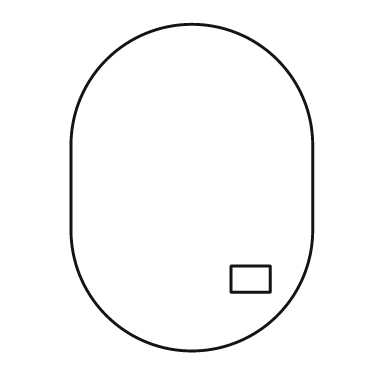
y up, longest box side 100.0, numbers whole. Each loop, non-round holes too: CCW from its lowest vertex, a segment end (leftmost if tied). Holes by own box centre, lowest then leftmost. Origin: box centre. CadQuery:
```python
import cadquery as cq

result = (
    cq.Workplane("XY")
    .moveTo(-37.0, -13.0)
    .threePointArc((0.0, -50.0), (37.0, -13.0))
    .lineTo(37.0, 13.0)
    .threePointArc((0.0, 50.0), (-37.0, 13.0))
    .close()
    .moveTo(12.0, -32.0)
    .lineTo(24.0, -32.0)
    .lineTo(24.0, -24.0)
    .lineTo(12.0, -24.0)
    .close()
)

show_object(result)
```